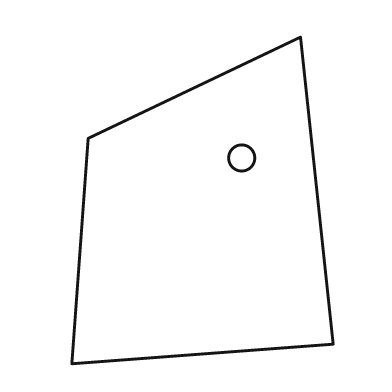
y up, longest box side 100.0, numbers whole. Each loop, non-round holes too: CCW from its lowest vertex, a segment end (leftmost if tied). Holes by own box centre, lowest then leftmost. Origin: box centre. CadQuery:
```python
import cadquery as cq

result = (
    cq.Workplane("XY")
    .moveTo(-40.0, -50.0)
    .lineTo(40.0, -44.0)
    .lineTo(30.0, 50.0)
    .lineTo(-35.0, 19.0)
    .close()
    .moveTo(12.0, 13.0)
    .circle(4.0)
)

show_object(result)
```